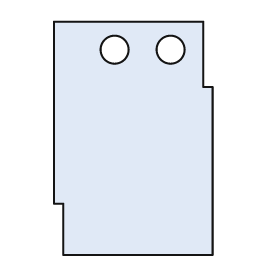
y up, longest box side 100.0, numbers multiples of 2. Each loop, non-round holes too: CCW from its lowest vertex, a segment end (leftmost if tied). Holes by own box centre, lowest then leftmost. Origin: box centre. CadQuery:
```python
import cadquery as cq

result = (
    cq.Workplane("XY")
    .moveTo(-30.0, -50.0)
    .lineTo(34.0, -50.0)
    .lineTo(34.0, 22.0)
    .lineTo(30.0, 22.0)
    .lineTo(30.0, 50.0)
    .lineTo(-34.0, 50.0)
    .lineTo(-34.0, -28.0)
    .lineTo(-30.0, -28.0)
    .close()
    .moveTo(-8.0, 38.0)
    .circle(6.0)
    .moveTo(16.0, 38.0)
    .circle(6.0)
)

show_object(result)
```